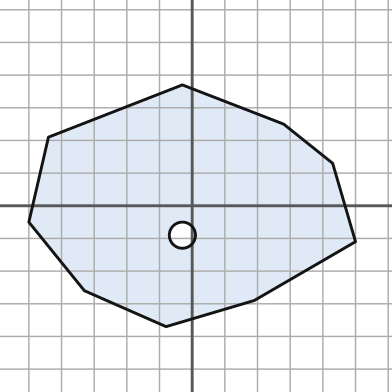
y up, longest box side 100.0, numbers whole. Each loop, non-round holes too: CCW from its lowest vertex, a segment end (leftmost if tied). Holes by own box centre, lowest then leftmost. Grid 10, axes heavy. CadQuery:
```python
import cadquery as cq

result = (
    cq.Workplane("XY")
    .moveTo(-8.0, -37.0)
    .lineTo(19.0, -29.0)
    .lineTo(50.0, -11.0)
    .lineTo(43.0, 13.0)
    .lineTo(28.0, 25.0)
    .lineTo(-3.0, 37.0)
    .lineTo(-44.0, 21.0)
    .lineTo(-50.0, -5.0)
    .lineTo(-33.0, -26.0)
    .close()
    .moveTo(-3.0, -9.0)
    .circle(4.0)
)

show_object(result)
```